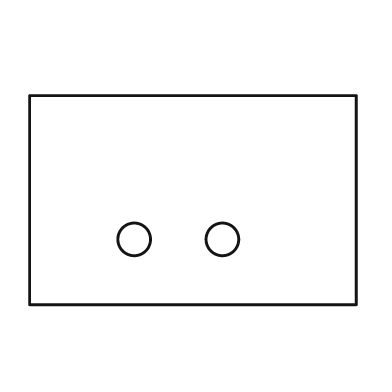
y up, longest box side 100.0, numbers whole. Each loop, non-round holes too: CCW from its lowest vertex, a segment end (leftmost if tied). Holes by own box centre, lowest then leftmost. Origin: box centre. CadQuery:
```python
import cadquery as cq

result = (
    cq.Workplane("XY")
    .moveTo(-50.0, -32.0)
    .lineTo(50.0, -32.0)
    .lineTo(50.0, 32.0)
    .lineTo(-50.0, 32.0)
    .close()
    .moveTo(-18.0, -12.0)
    .circle(5.0)
    .moveTo(9.0, -12.0)
    .circle(5.0)
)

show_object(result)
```